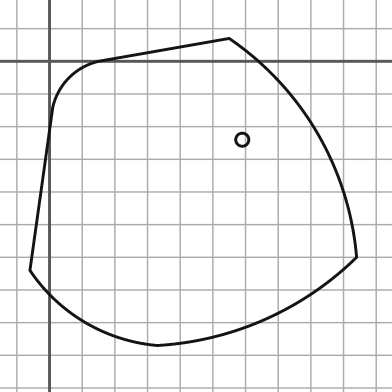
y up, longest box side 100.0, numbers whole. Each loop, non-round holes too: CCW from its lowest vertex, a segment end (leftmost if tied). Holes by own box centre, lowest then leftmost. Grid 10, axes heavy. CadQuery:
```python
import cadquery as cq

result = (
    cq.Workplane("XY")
    .moveTo(33.0, -87.0)
    .threePointArc((66.0, -79.0), (94.0, -60.0))
    .threePointArc((82.0, -22.0), (55.0, 7.0))
    .lineTo(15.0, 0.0)
    .threePointArc((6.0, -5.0), (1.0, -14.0))
    .lineTo(-6.0, -64.0)
    .threePointArc((11.0, -80.0), (33.0, -87.0))
    .close()
    .moveTo(59.0, -24.0)
    .circle(2.0)
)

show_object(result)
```